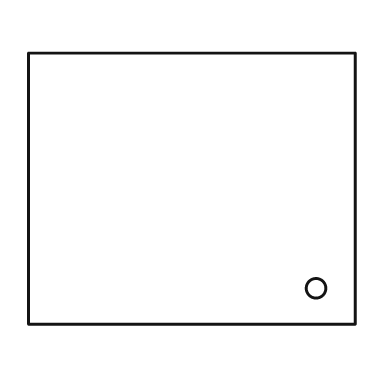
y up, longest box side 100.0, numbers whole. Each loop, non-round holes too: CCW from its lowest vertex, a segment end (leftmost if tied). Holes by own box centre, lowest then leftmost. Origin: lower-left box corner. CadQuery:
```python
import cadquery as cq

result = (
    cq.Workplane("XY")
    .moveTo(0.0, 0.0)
    .lineTo(100.0, 0.0)
    .lineTo(100.0, 83.0)
    .lineTo(0.0, 83.0)
    .close()
    .moveTo(88.0, 11.0)
    .circle(3.0)
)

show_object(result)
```